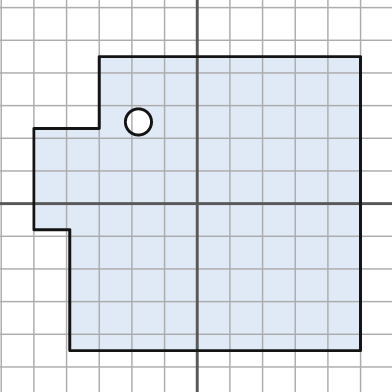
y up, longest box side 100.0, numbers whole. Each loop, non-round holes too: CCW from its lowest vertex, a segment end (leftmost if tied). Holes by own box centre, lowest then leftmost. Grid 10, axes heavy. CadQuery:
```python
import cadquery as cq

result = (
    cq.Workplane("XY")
    .moveTo(-39.0, -45.0)
    .lineTo(50.0, -45.0)
    .lineTo(50.0, 45.0)
    .lineTo(-30.0, 45.0)
    .lineTo(-30.0, 23.0)
    .lineTo(-50.0, 23.0)
    .lineTo(-50.0, -8.0)
    .lineTo(-39.0, -8.0)
    .close()
    .moveTo(-18.0, 25.0)
    .circle(4.0)
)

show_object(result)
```